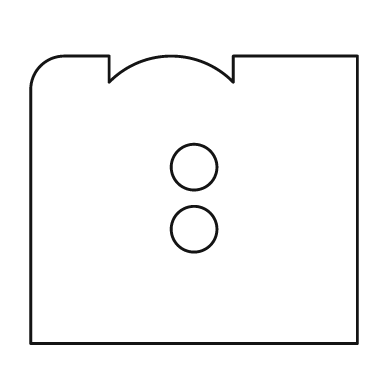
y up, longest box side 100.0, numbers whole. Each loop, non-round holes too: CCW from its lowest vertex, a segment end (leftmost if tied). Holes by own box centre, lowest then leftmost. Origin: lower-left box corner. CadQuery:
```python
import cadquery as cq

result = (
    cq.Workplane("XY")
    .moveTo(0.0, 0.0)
    .lineTo(100.0, 0.0)
    .lineTo(100.0, 88.0)
    .lineTo(62.0, 88.0)
    .lineTo(62.0, 80.0)
    .threePointArc((43.0, 88.0), (24.0, 80.0))
    .lineTo(24.0, 88.0)
    .lineTo(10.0, 88.0)
    .threePointArc((3.0, 85.0), (0.0, 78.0))
    .close()
    .moveTo(50.0, 35.0)
    .circle(7.0)
    .moveTo(50.0, 54.0)
    .circle(7.0)
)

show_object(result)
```